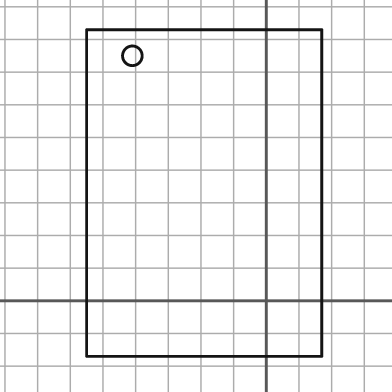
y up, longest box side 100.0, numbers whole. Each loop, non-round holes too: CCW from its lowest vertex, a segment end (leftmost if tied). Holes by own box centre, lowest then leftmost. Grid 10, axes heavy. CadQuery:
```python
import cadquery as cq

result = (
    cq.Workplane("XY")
    .moveTo(-55.0, -17.0)
    .lineTo(17.0, -17.0)
    .lineTo(17.0, 83.0)
    .lineTo(-55.0, 83.0)
    .close()
    .moveTo(-41.0, 75.0)
    .circle(3.0)
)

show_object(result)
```